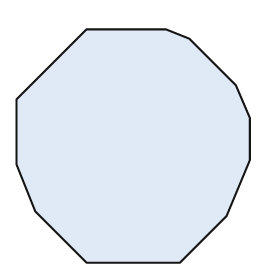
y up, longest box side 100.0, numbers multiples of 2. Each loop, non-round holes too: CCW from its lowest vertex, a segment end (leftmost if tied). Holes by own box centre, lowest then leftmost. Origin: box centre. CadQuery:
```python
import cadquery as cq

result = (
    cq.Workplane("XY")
    .moveTo(-20.0, -50.0)
    .lineTo(20.0, -50.0)
    .lineTo(40.0, -30.0)
    .lineTo(50.0, -6.0)
    .lineTo(50.0, 12.0)
    .lineTo(44.0, 26.0)
    .lineTo(24.0, 46.0)
    .lineTo(14.0, 50.0)
    .lineTo(-20.0, 50.0)
    .lineTo(-50.0, 20.0)
    .lineTo(-50.0, -8.0)
    .lineTo(-42.0, -28.0)
    .close()
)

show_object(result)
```